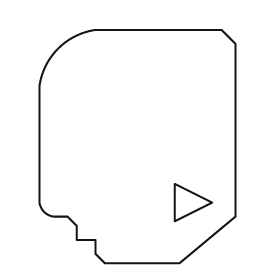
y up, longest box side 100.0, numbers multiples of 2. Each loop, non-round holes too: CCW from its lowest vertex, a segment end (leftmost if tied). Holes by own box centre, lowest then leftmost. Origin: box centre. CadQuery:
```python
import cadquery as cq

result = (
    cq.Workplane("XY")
    .moveTo(-14.0, -50.0)
    .lineTo(18.0, -50.0)
    .lineTo(42.0, -30.0)
    .lineTo(42.0, 44.0)
    .lineTo(36.0, 50.0)
    .lineTo(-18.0, 50.0)
    .threePointArc((-34.0, 42.0), (-42.0, 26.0))
    .lineTo(-42.0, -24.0)
    .threePointArc((-40.0, -28.0), (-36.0, -30.0))
    .lineTo(-30.0, -30.0)
    .lineTo(-26.0, -34.0)
    .lineTo(-26.0, -40.0)
    .lineTo(-18.0, -40.0)
    .lineTo(-18.0, -46.0)
    .close()
    .moveTo(16.0, -32.0)
    .lineTo(32.0, -24.0)
    .lineTo(16.0, -16.0)
    .close()
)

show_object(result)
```